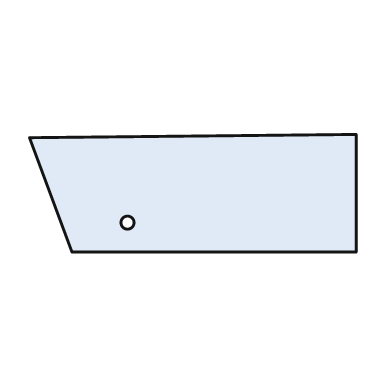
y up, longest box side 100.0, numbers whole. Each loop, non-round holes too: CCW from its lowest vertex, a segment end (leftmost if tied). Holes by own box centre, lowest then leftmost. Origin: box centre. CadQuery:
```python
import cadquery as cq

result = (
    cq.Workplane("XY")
    .moveTo(-37.0, -18.0)
    .lineTo(50.0, -18.0)
    .lineTo(50.0, 18.0)
    .lineTo(-50.0, 17.0)
    .close()
    .moveTo(-20.0, -9.0)
    .circle(2.0)
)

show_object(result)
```